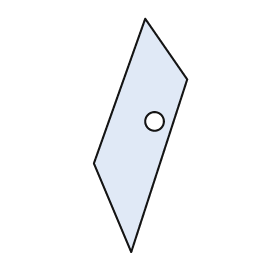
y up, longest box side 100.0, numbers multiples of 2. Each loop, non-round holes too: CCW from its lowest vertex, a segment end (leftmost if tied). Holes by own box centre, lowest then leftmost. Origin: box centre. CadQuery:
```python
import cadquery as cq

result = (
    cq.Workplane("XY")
    .moveTo(-4.0, -50.0)
    .lineTo(20.0, 24.0)
    .lineTo(2.0, 50.0)
    .lineTo(-20.0, -12.0)
    .close()
    .moveTo(6.0, 6.0)
    .circle(4.0)
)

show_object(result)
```